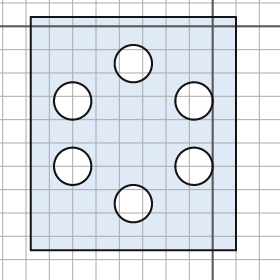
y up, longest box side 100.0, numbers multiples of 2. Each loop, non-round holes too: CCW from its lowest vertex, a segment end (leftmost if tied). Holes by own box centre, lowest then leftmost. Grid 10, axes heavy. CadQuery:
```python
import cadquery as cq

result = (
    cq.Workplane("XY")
    .moveTo(-78.0, -96.0)
    .lineTo(10.0, -96.0)
    .lineTo(10.0, 4.0)
    .lineTo(-78.0, 4.0)
    .close()
    .moveTo(-34.0, -76.0)
    .circle(8.0)
    .moveTo(-60.0, -60.0)
    .circle(8.0)
    .moveTo(-8.0, -60.0)
    .circle(8.0)
    .moveTo(-60.0, -32.0)
    .circle(8.0)
    .moveTo(-8.0, -32.0)
    .circle(8.0)
    .moveTo(-34.0, -16.0)
    .circle(8.0)
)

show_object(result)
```